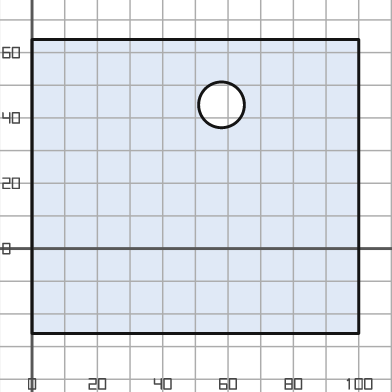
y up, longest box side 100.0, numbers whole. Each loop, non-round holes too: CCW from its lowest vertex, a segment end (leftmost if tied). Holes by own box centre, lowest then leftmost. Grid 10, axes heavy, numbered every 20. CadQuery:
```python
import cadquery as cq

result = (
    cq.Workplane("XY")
    .moveTo(0.0, -26.0)
    .lineTo(100.0, -26.0)
    .lineTo(100.0, 64.0)
    .lineTo(0.0, 64.0)
    .close()
    .moveTo(58.0, 44.0)
    .circle(7.0)
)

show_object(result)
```